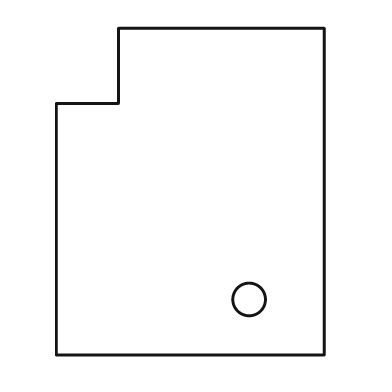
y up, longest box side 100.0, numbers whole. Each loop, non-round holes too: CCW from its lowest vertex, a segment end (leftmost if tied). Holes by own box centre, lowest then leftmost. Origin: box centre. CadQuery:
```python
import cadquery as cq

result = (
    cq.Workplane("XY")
    .moveTo(-41.0, -50.0)
    .lineTo(41.0, -50.0)
    .lineTo(41.0, 50.0)
    .lineTo(-22.0, 50.0)
    .lineTo(-22.0, 27.0)
    .lineTo(-41.0, 27.0)
    .close()
    .moveTo(18.0, -33.0)
    .circle(5.0)
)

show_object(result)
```